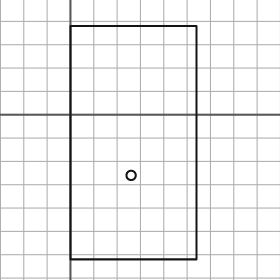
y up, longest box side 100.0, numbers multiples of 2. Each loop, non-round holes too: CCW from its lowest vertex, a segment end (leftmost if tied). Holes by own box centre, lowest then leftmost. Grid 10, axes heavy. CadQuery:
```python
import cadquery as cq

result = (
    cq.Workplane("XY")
    .moveTo(0.0, -62.0)
    .lineTo(54.0, -62.0)
    .lineTo(54.0, 38.0)
    .lineTo(0.0, 38.0)
    .close()
    .moveTo(26.0, -26.0)
    .circle(2.0)
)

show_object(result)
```